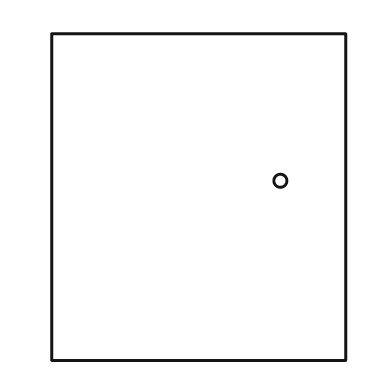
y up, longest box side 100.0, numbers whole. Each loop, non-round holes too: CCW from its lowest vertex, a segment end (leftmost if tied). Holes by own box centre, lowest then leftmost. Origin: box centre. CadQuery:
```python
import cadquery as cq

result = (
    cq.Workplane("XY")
    .moveTo(-45.0, -50.0)
    .lineTo(45.0, -50.0)
    .lineTo(45.0, 50.0)
    .lineTo(-45.0, 50.0)
    .close()
    .moveTo(25.0, 5.0)
    .circle(2.0)
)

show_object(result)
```